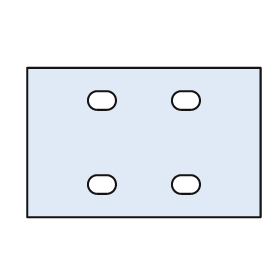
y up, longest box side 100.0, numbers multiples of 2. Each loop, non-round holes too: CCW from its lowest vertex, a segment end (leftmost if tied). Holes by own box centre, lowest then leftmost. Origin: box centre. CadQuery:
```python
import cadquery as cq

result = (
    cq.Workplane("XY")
    .moveTo(-50.0, -32.0)
    .lineTo(50.0, -32.0)
    .lineTo(50.0, 32.0)
    .lineTo(-50.0, 32.0)
    .close()
    .moveTo(-20.0, -22.0)
    .lineTo(-16.0, -22.0)
    .threePointArc((-12.0, -18.0), (-16.0, -14.0))
    .lineTo(-20.0, -14.0)
    .threePointArc((-24.0, -18.0), (-20.0, -22.0))
    .close()
    .moveTo(16.0, -22.0)
    .lineTo(20.0, -22.0)
    .threePointArc((24.0, -18.0), (20.0, -14.0))
    .lineTo(16.0, -14.0)
    .threePointArc((12.0, -18.0), (16.0, -22.0))
    .close()
    .moveTo(-20.0, 14.0)
    .lineTo(-16.0, 14.0)
    .threePointArc((-12.0, 18.0), (-16.0, 22.0))
    .lineTo(-20.0, 22.0)
    .threePointArc((-24.0, 18.0), (-20.0, 14.0))
    .close()
    .moveTo(16.0, 14.0)
    .lineTo(20.0, 14.0)
    .threePointArc((24.0, 18.0), (20.0, 22.0))
    .lineTo(16.0, 22.0)
    .threePointArc((12.0, 18.0), (16.0, 14.0))
    .close()
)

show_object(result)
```